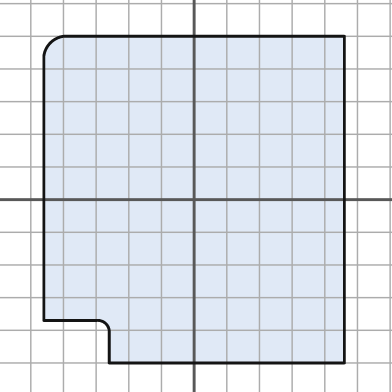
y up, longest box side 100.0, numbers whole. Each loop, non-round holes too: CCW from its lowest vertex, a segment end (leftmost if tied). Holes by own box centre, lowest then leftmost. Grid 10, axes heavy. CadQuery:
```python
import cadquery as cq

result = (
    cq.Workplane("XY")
    .moveTo(-26.0, -50.0)
    .lineTo(46.0, -50.0)
    .lineTo(46.0, 50.0)
    .lineTo(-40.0, 50.0)
    .threePointArc((-44.0, 48.0), (-46.0, 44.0))
    .lineTo(-46.0, -37.0)
    .lineTo(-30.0, -37.0)
    .threePointArc((-27.0, -38.0), (-26.0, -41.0))
    .close()
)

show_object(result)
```